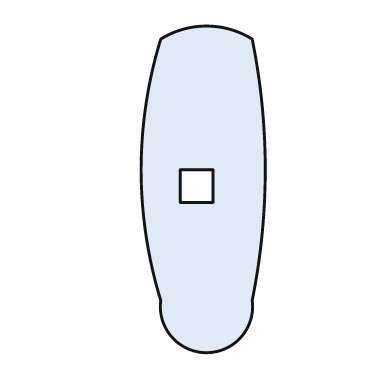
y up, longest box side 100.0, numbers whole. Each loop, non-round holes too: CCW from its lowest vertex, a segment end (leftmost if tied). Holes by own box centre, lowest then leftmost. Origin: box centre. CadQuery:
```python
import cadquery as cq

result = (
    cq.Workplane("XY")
    .moveTo(-13.0, -34.0)
    .threePointArc((1.0, -50.0), (15.0, -34.0))
    .threePointArc((19.0, 6.0), (15.0, 46.0))
    .threePointArc((1.0, 50.0), (-13.0, 46.0))
    .threePointArc((-19.0, 6.0), (-13.0, -34.0))
    .close()
    .moveTo(-7.0, -4.0)
    .lineTo(3.0, -4.0)
    .lineTo(3.0, 6.0)
    .lineTo(-7.0, 6.0)
    .close()
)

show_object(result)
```